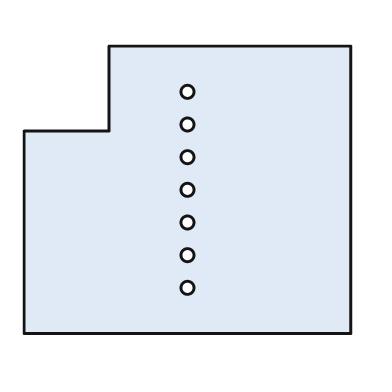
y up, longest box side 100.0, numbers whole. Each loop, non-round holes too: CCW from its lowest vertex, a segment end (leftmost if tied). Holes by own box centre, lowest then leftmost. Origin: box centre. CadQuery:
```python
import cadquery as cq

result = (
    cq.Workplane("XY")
    .moveTo(-50.0, -44.0)
    .lineTo(50.0, -44.0)
    .lineTo(50.0, 44.0)
    .lineTo(-24.0, 44.0)
    .lineTo(-24.0, 18.0)
    .lineTo(-50.0, 18.0)
    .close()
    .moveTo(0.0, -30.0)
    .circle(2.0)
    .moveTo(0.0, -20.0)
    .circle(2.0)
    .moveTo(0.0, -10.0)
    .circle(2.0)
    .moveTo(0.0, 0.0)
    .circle(2.0)
    .moveTo(0.0, 10.0)
    .circle(2.0)
    .moveTo(0.0, 20.0)
    .circle(2.0)
    .moveTo(0.0, 30.0)
    .circle(2.0)
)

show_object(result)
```